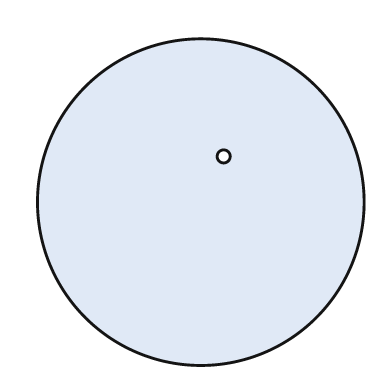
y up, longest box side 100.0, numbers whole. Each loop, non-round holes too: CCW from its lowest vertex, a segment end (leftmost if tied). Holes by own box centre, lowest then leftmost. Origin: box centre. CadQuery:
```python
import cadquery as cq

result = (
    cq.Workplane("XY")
    .moveTo(0.0, 0.0)
    .circle(50.0)
    .moveTo(7.0, 14.0)
    .circle(2.0)
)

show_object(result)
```